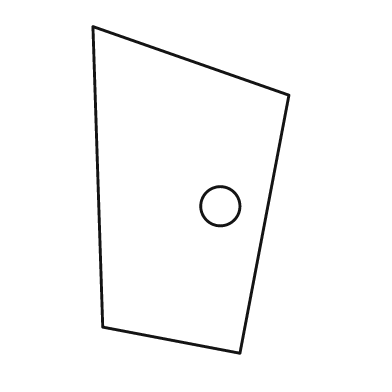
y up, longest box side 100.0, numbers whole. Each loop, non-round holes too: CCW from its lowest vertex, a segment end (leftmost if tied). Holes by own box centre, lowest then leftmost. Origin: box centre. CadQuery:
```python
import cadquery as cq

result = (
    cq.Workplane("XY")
    .moveTo(15.0, -50.0)
    .lineTo(30.0, 29.0)
    .lineTo(-30.0, 50.0)
    .lineTo(-27.0, -42.0)
    .close()
    .moveTo(9.0, -5.0)
    .circle(6.0)
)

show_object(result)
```